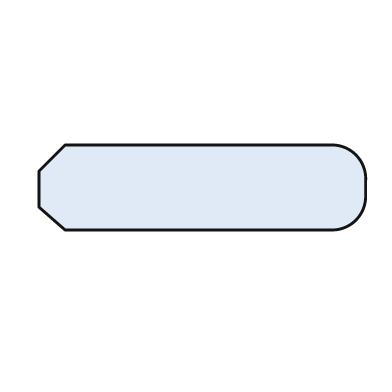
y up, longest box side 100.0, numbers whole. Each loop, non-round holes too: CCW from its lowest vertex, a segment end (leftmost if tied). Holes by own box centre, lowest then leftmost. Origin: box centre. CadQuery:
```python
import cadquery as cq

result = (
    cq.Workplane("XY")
    .moveTo(-42.0, -13.0)
    .lineTo(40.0, -13.0)
    .threePointArc((47.0, -10.0), (50.0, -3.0))
    .lineTo(50.0, 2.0)
    .threePointArc((47.0, 10.0), (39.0, 13.0))
    .lineTo(-42.0, 13.0)
    .lineTo(-50.0, 5.0)
    .lineTo(-50.0, -6.0)
    .close()
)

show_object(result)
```